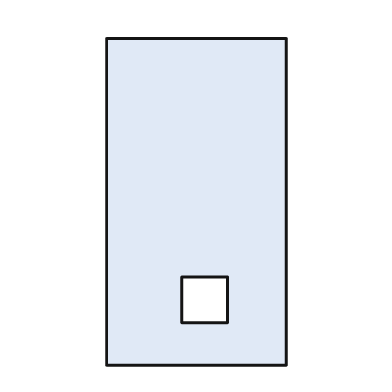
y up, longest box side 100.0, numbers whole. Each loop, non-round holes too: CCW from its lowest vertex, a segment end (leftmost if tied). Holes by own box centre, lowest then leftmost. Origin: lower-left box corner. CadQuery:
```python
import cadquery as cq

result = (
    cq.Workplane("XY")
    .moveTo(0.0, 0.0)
    .lineTo(55.0, 0.0)
    .lineTo(55.0, 100.0)
    .lineTo(0.0, 100.0)
    .close()
    .moveTo(23.0, 13.0)
    .lineTo(37.0, 13.0)
    .lineTo(37.0, 27.0)
    .lineTo(23.0, 27.0)
    .close()
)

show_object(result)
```